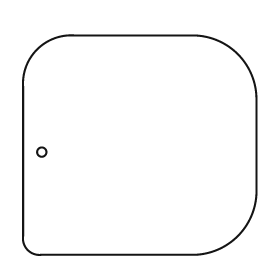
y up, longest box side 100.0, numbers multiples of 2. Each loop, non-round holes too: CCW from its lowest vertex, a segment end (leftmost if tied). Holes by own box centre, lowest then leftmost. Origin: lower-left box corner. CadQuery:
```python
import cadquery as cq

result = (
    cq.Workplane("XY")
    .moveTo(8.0, 0.0)
    .lineTo(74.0, 0.0)
    .threePointArc((92.0, 8.0), (100.0, 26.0))
    .lineTo(100.0, 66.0)
    .threePointArc((92.0, 86.0), (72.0, 94.0))
    .lineTo(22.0, 94.0)
    .threePointArc((6.0, 88.0), (0.0, 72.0))
    .lineTo(0.0, 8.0)
    .threePointArc((2.0, 2.0), (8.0, 0.0))
    .close()
    .moveTo(8.0, 44.0)
    .circle(2.0)
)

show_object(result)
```